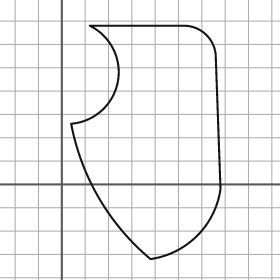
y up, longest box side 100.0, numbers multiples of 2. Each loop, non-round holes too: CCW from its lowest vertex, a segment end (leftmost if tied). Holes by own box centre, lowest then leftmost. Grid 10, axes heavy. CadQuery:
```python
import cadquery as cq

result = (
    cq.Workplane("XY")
    .moveTo(38.0, -32.0)
    .threePointArc((58.0, -22.0), (68.0, -2.0))
    .lineTo(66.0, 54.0)
    .threePointArc((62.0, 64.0), (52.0, 68.0))
    .lineTo(12.0, 68.0)
    .threePointArc((24.0, 44.0), (4.0, 26.0))
    .threePointArc((16.0, -6.0), (38.0, -32.0))
    .close()
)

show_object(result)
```